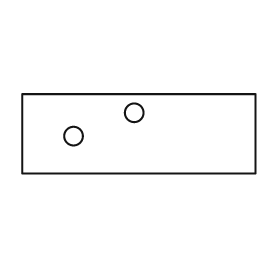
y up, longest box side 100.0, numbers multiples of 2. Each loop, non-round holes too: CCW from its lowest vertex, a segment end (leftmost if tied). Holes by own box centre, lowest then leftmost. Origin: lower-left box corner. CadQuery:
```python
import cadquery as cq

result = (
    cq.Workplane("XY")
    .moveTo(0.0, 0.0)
    .lineTo(100.0, 0.0)
    .lineTo(100.0, 34.0)
    .lineTo(0.0, 34.0)
    .close()
    .moveTo(22.0, 16.0)
    .circle(4.0)
    .moveTo(48.0, 26.0)
    .circle(4.0)
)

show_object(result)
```